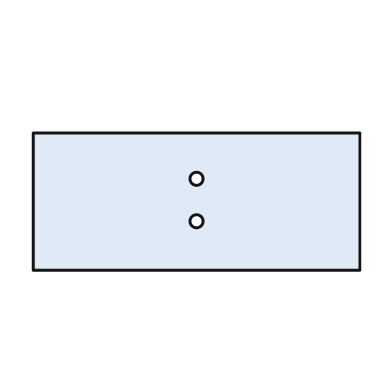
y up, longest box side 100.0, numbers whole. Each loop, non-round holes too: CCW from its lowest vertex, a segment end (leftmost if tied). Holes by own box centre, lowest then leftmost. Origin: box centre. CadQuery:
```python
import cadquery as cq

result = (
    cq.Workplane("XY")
    .moveTo(-50.0, -21.0)
    .lineTo(50.0, -21.0)
    .lineTo(50.0, 21.0)
    .lineTo(-50.0, 21.0)
    .close()
    .moveTo(0.0, -6.0)
    .circle(2.0)
    .moveTo(0.0, 7.0)
    .circle(2.0)
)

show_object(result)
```